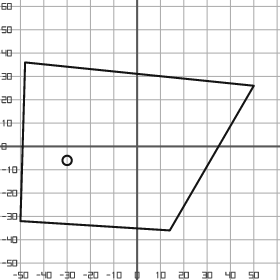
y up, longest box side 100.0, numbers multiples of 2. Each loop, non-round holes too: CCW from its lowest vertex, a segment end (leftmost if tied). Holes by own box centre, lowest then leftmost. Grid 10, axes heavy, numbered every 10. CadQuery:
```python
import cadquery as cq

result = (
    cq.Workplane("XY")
    .moveTo(14.0, -36.0)
    .lineTo(50.0, 26.0)
    .lineTo(-48.0, 36.0)
    .lineTo(-50.0, -32.0)
    .close()
    .moveTo(-30.0, -6.0)
    .circle(2.0)
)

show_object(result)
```